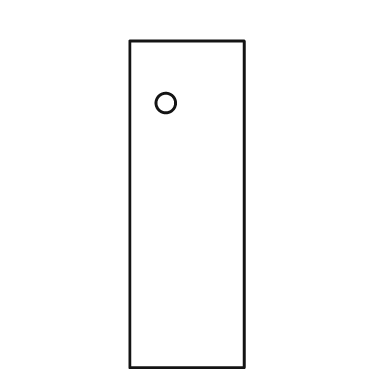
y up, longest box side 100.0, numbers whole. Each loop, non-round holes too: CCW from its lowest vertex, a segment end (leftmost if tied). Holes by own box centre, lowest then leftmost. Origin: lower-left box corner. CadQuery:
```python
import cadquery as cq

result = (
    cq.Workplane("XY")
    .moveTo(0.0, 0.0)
    .lineTo(35.0, 0.0)
    .lineTo(35.0, 100.0)
    .lineTo(0.0, 100.0)
    .close()
    .moveTo(11.0, 81.0)
    .circle(3.0)
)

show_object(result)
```